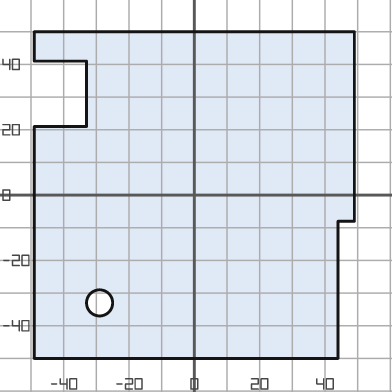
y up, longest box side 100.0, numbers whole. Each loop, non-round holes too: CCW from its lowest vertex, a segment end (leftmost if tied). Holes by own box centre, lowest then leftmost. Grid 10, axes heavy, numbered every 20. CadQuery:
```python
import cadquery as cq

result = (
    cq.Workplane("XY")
    .moveTo(-49.0, -50.0)
    .lineTo(44.0, -50.0)
    .lineTo(44.0, -8.0)
    .lineTo(49.0, -8.0)
    .lineTo(49.0, 50.0)
    .lineTo(-49.0, 50.0)
    .lineTo(-49.0, 41.0)
    .lineTo(-33.0, 41.0)
    .lineTo(-33.0, 21.0)
    .lineTo(-49.0, 21.0)
    .close()
    .moveTo(-29.0, -33.0)
    .circle(4.0)
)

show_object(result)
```